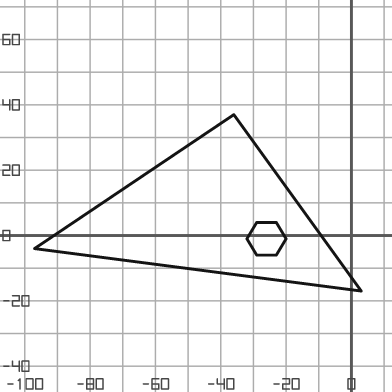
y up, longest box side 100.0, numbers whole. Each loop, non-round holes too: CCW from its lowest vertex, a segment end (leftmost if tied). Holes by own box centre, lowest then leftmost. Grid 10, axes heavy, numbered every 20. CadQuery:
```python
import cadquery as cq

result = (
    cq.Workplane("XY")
    .moveTo(3.0, -17.0)
    .lineTo(-36.0, 37.0)
    .lineTo(-97.0, -4.0)
    .close()
    .moveTo(-29.0, -6.0)
    .lineTo(-23.0, -6.0)
    .lineTo(-20.0, -1.0)
    .lineTo(-23.0, 4.0)
    .lineTo(-29.0, 4.0)
    .lineTo(-32.0, -1.0)
    .close()
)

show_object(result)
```